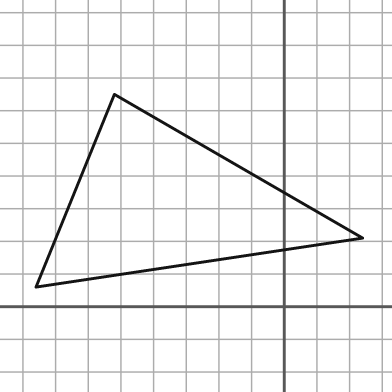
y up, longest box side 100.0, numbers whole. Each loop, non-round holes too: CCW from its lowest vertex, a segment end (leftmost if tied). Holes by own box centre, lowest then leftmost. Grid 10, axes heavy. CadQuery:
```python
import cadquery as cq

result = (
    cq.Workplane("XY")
    .moveTo(-76.0, 6.0)
    .lineTo(24.0, 21.0)
    .lineTo(-52.0, 65.0)
    .close()
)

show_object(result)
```